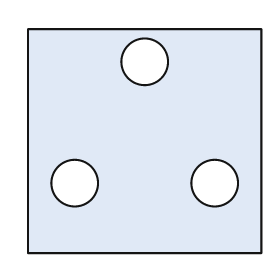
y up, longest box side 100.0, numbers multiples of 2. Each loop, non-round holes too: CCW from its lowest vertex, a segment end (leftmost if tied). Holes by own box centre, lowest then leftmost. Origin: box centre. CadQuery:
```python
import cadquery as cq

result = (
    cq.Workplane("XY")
    .moveTo(-50.0, -48.0)
    .lineTo(50.0, -48.0)
    .lineTo(50.0, 48.0)
    .lineTo(-50.0, 48.0)
    .close()
    .moveTo(-30.0, -18.0)
    .circle(10.0)
    .moveTo(30.0, -18.0)
    .circle(10.0)
    .moveTo(0.0, 34.0)
    .circle(10.0)
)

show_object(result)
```